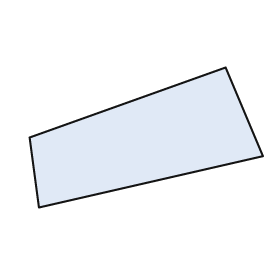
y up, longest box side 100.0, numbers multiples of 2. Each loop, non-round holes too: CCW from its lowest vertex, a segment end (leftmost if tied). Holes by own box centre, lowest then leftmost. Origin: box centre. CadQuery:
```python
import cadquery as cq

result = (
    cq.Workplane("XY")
    .moveTo(-46.0, -30.0)
    .lineTo(50.0, -8.0)
    .lineTo(34.0, 30.0)
    .lineTo(-50.0, 0.0)
    .close()
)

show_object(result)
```